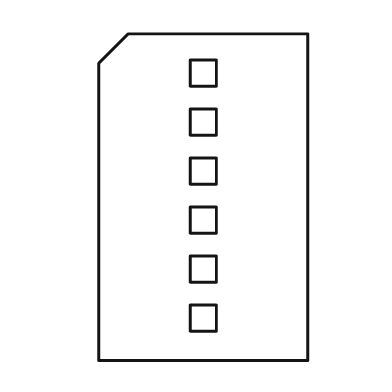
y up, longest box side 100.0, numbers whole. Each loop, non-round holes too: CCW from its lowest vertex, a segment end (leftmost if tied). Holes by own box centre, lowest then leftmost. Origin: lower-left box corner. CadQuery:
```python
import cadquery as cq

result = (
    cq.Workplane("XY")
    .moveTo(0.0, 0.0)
    .lineTo(64.0, 0.0)
    .lineTo(64.0, 100.0)
    .lineTo(9.0, 100.0)
    .lineTo(0.0, 91.0)
    .close()
    .moveTo(28.0, 9.0)
    .lineTo(36.0, 9.0)
    .lineTo(36.0, 17.0)
    .lineTo(28.0, 17.0)
    .close()
    .moveTo(28.0, 24.0)
    .lineTo(36.0, 24.0)
    .lineTo(36.0, 32.0)
    .lineTo(28.0, 32.0)
    .close()
    .moveTo(28.0, 39.0)
    .lineTo(36.0, 39.0)
    .lineTo(36.0, 47.0)
    .lineTo(28.0, 47.0)
    .close()
    .moveTo(28.0, 54.0)
    .lineTo(36.0, 54.0)
    .lineTo(36.0, 62.0)
    .lineTo(28.0, 62.0)
    .close()
    .moveTo(28.0, 69.0)
    .lineTo(36.0, 69.0)
    .lineTo(36.0, 77.0)
    .lineTo(28.0, 77.0)
    .close()
    .moveTo(28.0, 84.0)
    .lineTo(36.0, 84.0)
    .lineTo(36.0, 92.0)
    .lineTo(28.0, 92.0)
    .close()
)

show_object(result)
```